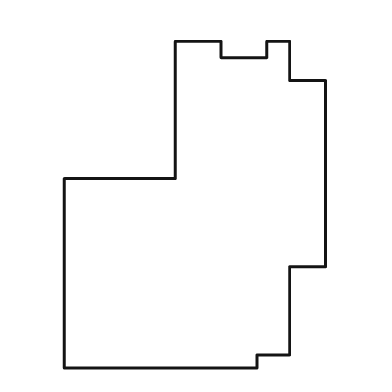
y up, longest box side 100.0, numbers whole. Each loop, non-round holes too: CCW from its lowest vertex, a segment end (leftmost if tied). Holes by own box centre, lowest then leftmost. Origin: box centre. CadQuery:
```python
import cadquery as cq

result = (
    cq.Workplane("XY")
    .moveTo(-40.0, -50.0)
    .lineTo(19.0, -50.0)
    .lineTo(19.0, -46.0)
    .lineTo(29.0, -46.0)
    .lineTo(29.0, -19.0)
    .lineTo(40.0, -19.0)
    .lineTo(40.0, 38.0)
    .lineTo(29.0, 38.0)
    .lineTo(29.0, 50.0)
    .lineTo(22.0, 50.0)
    .lineTo(22.0, 45.0)
    .lineTo(8.0, 45.0)
    .lineTo(8.0, 50.0)
    .lineTo(-6.0, 50.0)
    .lineTo(-6.0, 8.0)
    .lineTo(-40.0, 8.0)
    .close()
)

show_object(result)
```